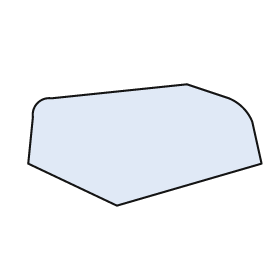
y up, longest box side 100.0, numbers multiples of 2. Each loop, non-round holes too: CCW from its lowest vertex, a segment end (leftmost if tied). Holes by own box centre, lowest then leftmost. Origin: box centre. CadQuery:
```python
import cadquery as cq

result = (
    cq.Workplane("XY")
    .moveTo(-12.0, -26.0)
    .lineTo(50.0, -8.0)
    .lineTo(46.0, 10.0)
    .threePointArc((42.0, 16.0), (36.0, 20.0))
    .lineTo(18.0, 26.0)
    .lineTo(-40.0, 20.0)
    .threePointArc((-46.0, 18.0), (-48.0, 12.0))
    .lineTo(-50.0, -8.0)
    .close()
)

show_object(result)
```